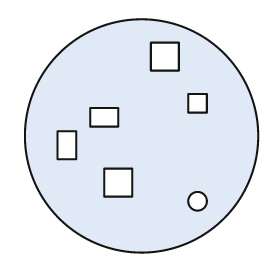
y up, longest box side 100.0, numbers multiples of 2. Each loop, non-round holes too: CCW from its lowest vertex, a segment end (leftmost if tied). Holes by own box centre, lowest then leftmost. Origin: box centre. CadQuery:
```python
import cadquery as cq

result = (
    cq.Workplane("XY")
    .moveTo(0.0, 0.0)
    .circle(50.0)
    .moveTo(24.0, -28.0)
    .circle(4.0)
    .moveTo(-16.0, -26.0)
    .lineTo(-4.0, -26.0)
    .lineTo(-4.0, -14.0)
    .lineTo(-16.0, -14.0)
    .close()
    .moveTo(-36.0, -10.0)
    .lineTo(-28.0, -10.0)
    .lineTo(-28.0, 2.0)
    .lineTo(-36.0, 2.0)
    .close()
    .moveTo(-22.0, 4.0)
    .lineTo(-10.0, 4.0)
    .lineTo(-10.0, 12.0)
    .lineTo(-22.0, 12.0)
    .close()
    .moveTo(20.0, 10.0)
    .lineTo(28.0, 10.0)
    .lineTo(28.0, 18.0)
    .lineTo(20.0, 18.0)
    .close()
    .moveTo(4.0, 28.0)
    .lineTo(16.0, 28.0)
    .lineTo(16.0, 40.0)
    .lineTo(4.0, 40.0)
    .close()
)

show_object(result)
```